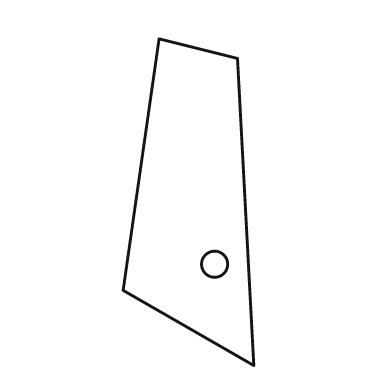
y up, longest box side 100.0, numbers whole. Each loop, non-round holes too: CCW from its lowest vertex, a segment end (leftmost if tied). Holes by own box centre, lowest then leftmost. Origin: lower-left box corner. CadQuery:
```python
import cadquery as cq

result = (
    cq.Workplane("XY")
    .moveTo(40.0, 0.0)
    .lineTo(35.0, 94.0)
    .lineTo(11.0, 100.0)
    .lineTo(0.0, 23.0)
    .close()
    .moveTo(28.0, 31.0)
    .circle(4.0)
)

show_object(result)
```